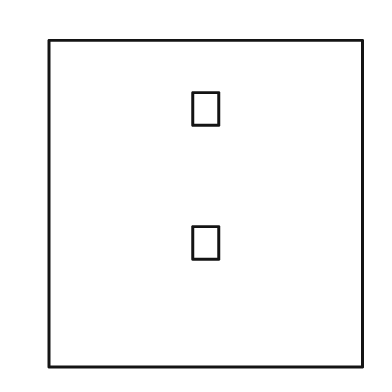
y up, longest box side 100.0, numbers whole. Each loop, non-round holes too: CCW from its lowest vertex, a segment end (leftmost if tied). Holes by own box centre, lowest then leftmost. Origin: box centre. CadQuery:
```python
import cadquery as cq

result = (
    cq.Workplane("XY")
    .moveTo(-48.0, -50.0)
    .lineTo(48.0, -50.0)
    .lineTo(48.0, 50.0)
    .lineTo(-48.0, 50.0)
    .close()
    .moveTo(-4.0, -17.0)
    .lineTo(4.0, -17.0)
    .lineTo(4.0, -7.0)
    .lineTo(-4.0, -7.0)
    .close()
    .moveTo(-4.0, 24.0)
    .lineTo(4.0, 24.0)
    .lineTo(4.0, 34.0)
    .lineTo(-4.0, 34.0)
    .close()
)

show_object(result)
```